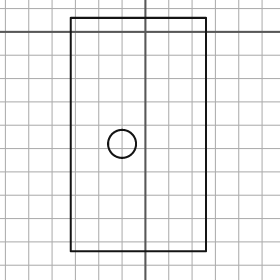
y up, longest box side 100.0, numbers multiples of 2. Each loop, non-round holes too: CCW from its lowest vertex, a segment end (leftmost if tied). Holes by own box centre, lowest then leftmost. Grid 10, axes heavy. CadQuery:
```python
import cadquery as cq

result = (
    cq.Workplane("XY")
    .moveTo(-32.0, -94.0)
    .lineTo(26.0, -94.0)
    .lineTo(26.0, 6.0)
    .lineTo(-32.0, 6.0)
    .close()
    .moveTo(-10.0, -48.0)
    .circle(6.0)
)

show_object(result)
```